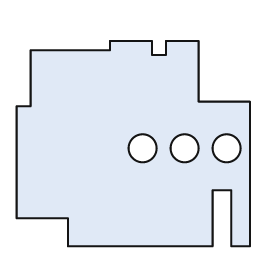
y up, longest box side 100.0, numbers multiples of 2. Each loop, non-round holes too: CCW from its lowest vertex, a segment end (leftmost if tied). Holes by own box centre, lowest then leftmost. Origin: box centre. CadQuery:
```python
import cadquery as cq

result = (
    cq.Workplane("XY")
    .moveTo(-28.0, -44.0)
    .lineTo(34.0, -44.0)
    .lineTo(34.0, -20.0)
    .lineTo(42.0, -20.0)
    .lineTo(42.0, -44.0)
    .lineTo(50.0, -44.0)
    .lineTo(50.0, 18.0)
    .lineTo(28.0, 18.0)
    .lineTo(28.0, 44.0)
    .lineTo(14.0, 44.0)
    .lineTo(14.0, 38.0)
    .lineTo(8.0, 38.0)
    .lineTo(8.0, 44.0)
    .lineTo(-10.0, 44.0)
    .lineTo(-10.0, 40.0)
    .lineTo(-44.0, 40.0)
    .lineTo(-44.0, 16.0)
    .lineTo(-50.0, 16.0)
    .lineTo(-50.0, -32.0)
    .lineTo(-28.0, -32.0)
    .close()
    .moveTo(4.0, -2.0)
    .circle(6.0)
    .moveTo(22.0, -2.0)
    .circle(6.0)
    .moveTo(40.0, -2.0)
    .circle(6.0)
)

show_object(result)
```